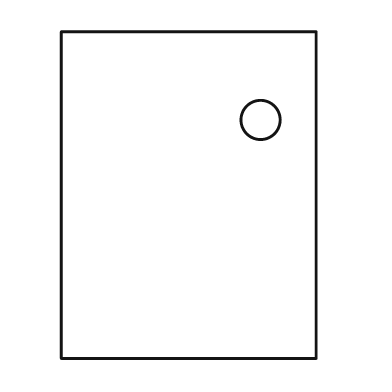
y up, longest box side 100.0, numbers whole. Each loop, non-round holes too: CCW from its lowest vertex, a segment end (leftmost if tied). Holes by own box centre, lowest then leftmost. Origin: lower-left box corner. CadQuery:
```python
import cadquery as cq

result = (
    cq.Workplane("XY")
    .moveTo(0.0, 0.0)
    .lineTo(78.0, 0.0)
    .lineTo(78.0, 100.0)
    .lineTo(0.0, 100.0)
    .close()
    .moveTo(61.0, 73.0)
    .circle(6.0)
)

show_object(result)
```